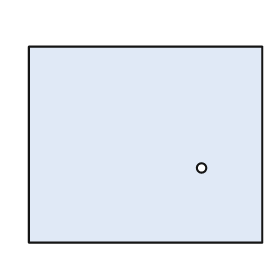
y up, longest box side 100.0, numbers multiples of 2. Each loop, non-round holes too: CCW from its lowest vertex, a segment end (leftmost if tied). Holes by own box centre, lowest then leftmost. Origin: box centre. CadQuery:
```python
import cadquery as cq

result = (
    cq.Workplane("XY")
    .moveTo(-50.0, -42.0)
    .lineTo(50.0, -42.0)
    .lineTo(50.0, 42.0)
    .lineTo(-50.0, 42.0)
    .close()
    .moveTo(24.0, -10.0)
    .circle(2.0)
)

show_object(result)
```